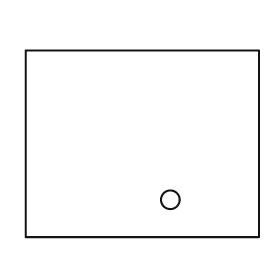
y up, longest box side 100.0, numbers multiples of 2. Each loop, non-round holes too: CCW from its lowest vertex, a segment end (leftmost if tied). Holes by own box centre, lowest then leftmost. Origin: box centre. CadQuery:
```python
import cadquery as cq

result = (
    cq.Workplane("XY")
    .moveTo(-50.0, -40.0)
    .lineTo(50.0, -40.0)
    .lineTo(50.0, 40.0)
    .lineTo(-50.0, 40.0)
    .close()
    .moveTo(12.0, -24.0)
    .circle(4.0)
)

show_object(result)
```